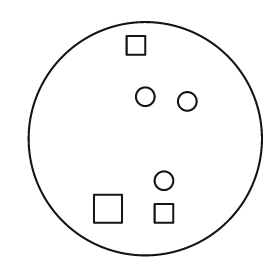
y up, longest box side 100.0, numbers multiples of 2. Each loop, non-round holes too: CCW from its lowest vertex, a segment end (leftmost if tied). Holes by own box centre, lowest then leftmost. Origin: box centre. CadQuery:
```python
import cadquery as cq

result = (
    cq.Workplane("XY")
    .moveTo(0.0, 0.0)
    .circle(50.0)
    .moveTo(4.0, -36.0)
    .lineTo(12.0, -36.0)
    .lineTo(12.0, -28.0)
    .lineTo(4.0, -28.0)
    .close()
    .moveTo(-22.0, -36.0)
    .lineTo(-10.0, -36.0)
    .lineTo(-10.0, -24.0)
    .lineTo(-22.0, -24.0)
    .close()
    .moveTo(8.0, -18.0)
    .circle(4.0)
    .moveTo(18.0, 16.0)
    .circle(4.0)
    .moveTo(0.0, 18.0)
    .circle(4.0)
    .moveTo(-8.0, 36.0)
    .lineTo(0.0, 36.0)
    .lineTo(0.0, 44.0)
    .lineTo(-8.0, 44.0)
    .close()
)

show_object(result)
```